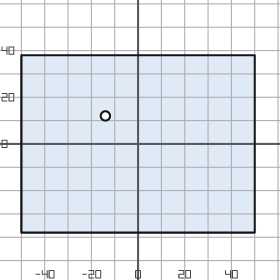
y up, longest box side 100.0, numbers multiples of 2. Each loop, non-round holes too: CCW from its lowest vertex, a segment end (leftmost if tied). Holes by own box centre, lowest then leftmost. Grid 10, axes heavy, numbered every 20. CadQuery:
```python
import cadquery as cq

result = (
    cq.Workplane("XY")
    .moveTo(-50.0, -38.0)
    .lineTo(50.0, -38.0)
    .lineTo(50.0, 38.0)
    .lineTo(-50.0, 38.0)
    .close()
    .moveTo(-14.0, 12.0)
    .circle(2.0)
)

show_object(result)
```